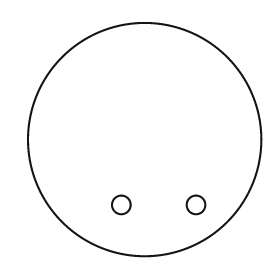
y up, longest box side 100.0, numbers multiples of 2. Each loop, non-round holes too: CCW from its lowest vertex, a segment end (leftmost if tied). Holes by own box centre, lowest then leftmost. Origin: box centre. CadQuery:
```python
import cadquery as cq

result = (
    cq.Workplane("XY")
    .moveTo(0.0, 0.0)
    .circle(50.0)
    .moveTo(-10.0, -28.0)
    .circle(4.0)
    .moveTo(22.0, -28.0)
    .circle(4.0)
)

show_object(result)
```